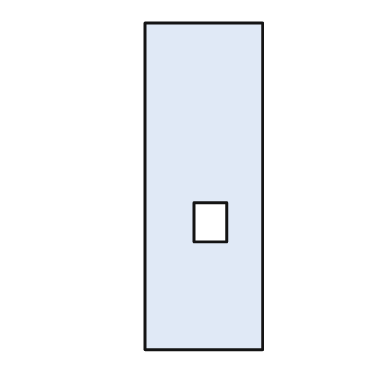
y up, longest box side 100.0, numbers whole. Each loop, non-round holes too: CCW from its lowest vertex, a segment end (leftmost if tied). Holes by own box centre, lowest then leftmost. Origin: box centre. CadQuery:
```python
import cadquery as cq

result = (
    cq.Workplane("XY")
    .moveTo(-18.0, -50.0)
    .lineTo(18.0, -50.0)
    .lineTo(18.0, 50.0)
    .lineTo(-18.0, 50.0)
    .close()
    .moveTo(-3.0, -17.0)
    .lineTo(7.0, -17.0)
    .lineTo(7.0, -5.0)
    .lineTo(-3.0, -5.0)
    .close()
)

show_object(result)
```